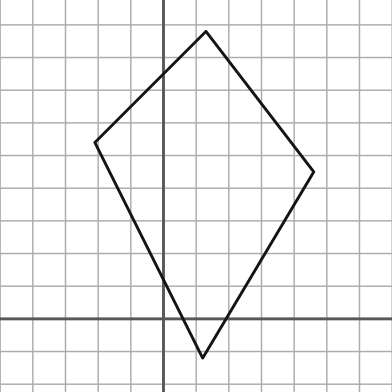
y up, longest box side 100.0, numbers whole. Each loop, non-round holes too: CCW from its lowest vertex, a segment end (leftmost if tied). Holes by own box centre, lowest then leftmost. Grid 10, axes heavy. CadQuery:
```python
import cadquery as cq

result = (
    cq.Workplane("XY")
    .moveTo(12.0, -12.0)
    .lineTo(46.0, 45.0)
    .lineTo(13.0, 88.0)
    .lineTo(-21.0, 54.0)
    .close()
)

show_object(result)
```